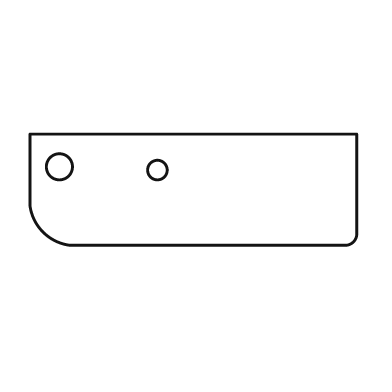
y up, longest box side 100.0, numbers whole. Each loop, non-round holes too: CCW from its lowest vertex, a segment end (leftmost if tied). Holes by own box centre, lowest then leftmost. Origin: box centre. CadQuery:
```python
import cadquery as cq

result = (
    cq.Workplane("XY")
    .moveTo(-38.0, -17.0)
    .lineTo(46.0, -17.0)
    .threePointArc((49.0, -16.0), (50.0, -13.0))
    .lineTo(50.0, 17.0)
    .lineTo(-50.0, 17.0)
    .lineTo(-50.0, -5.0)
    .threePointArc((-46.0, -13.0), (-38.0, -17.0))
    .close()
    .moveTo(-11.0, 6.0)
    .circle(3.0)
    .moveTo(-41.0, 7.0)
    .circle(4.0)
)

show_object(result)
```